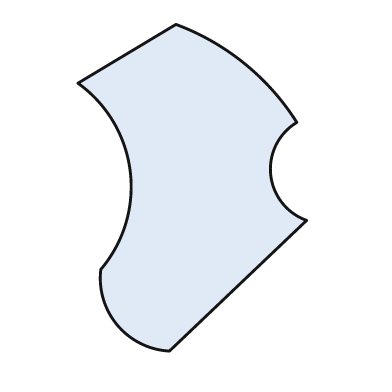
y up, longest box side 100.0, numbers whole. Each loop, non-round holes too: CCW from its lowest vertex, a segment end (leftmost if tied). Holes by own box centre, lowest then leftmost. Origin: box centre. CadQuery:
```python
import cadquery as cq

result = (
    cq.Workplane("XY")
    .moveTo(-7.0, -50.0)
    .lineTo(35.0, -10.0)
    .threePointArc((24.0, 4.0), (32.0, 20.0))
    .threePointArc((16.0, 38.0), (-5.0, 50.0))
    .lineTo(-35.0, 32.0)
    .threePointArc((-19.0, 5.0), (-28.0, -25.0))
    .threePointArc((-23.0, -42.0), (-7.0, -50.0))
    .close()
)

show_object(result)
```